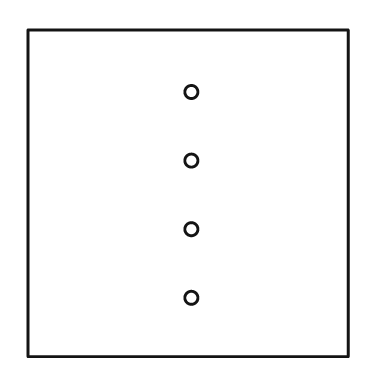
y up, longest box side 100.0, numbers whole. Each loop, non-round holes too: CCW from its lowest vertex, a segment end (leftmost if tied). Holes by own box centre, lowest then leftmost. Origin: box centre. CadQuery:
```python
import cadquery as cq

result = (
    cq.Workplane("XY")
    .moveTo(-49.0, -50.0)
    .lineTo(49.0, -50.0)
    .lineTo(49.0, 50.0)
    .lineTo(-49.0, 50.0)
    .close()
    .moveTo(1.0, -32.0)
    .circle(2.0)
    .moveTo(1.0, -11.0)
    .circle(2.0)
    .moveTo(1.0, 10.0)
    .circle(2.0)
    .moveTo(1.0, 31.0)
    .circle(2.0)
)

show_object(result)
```